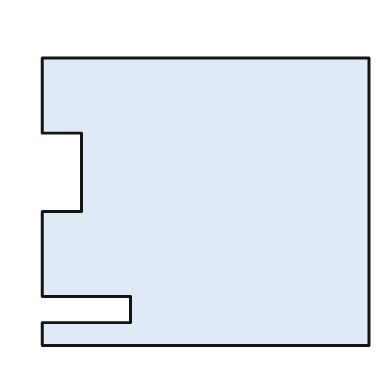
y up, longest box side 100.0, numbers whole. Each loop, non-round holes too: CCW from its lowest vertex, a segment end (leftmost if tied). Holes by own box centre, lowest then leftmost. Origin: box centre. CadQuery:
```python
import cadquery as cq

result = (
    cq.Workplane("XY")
    .moveTo(-50.0, -44.0)
    .lineTo(50.0, -44.0)
    .lineTo(50.0, 44.0)
    .lineTo(-50.0, 44.0)
    .lineTo(-50.0, 21.0)
    .lineTo(-38.0, 21.0)
    .lineTo(-38.0, -3.0)
    .lineTo(-50.0, -3.0)
    .lineTo(-50.0, -29.0)
    .lineTo(-23.0, -29.0)
    .lineTo(-23.0, -37.0)
    .lineTo(-50.0, -37.0)
    .close()
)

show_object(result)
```